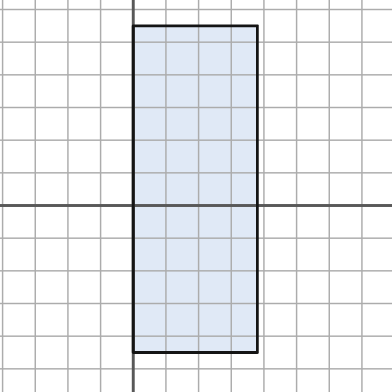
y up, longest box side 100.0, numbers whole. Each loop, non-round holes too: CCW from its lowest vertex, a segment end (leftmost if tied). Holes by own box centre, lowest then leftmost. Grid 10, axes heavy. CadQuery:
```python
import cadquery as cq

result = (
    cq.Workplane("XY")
    .moveTo(0.0, -45.0)
    .lineTo(38.0, -45.0)
    .lineTo(38.0, 55.0)
    .lineTo(0.0, 55.0)
    .close()
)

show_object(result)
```